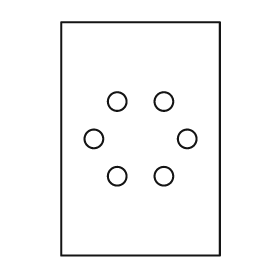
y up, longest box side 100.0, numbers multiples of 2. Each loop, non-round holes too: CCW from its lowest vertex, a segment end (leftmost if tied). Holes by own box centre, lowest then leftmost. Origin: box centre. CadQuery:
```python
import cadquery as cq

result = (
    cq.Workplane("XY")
    .moveTo(-34.0, -50.0)
    .lineTo(34.0, -50.0)
    .lineTo(34.0, 50.0)
    .lineTo(-34.0, 50.0)
    .close()
    .moveTo(-10.0, -16.0)
    .circle(4.0)
    .moveTo(10.0, -16.0)
    .circle(4.0)
    .moveTo(-20.0, 0.0)
    .circle(4.0)
    .moveTo(20.0, 0.0)
    .circle(4.0)
    .moveTo(-10.0, 16.0)
    .circle(4.0)
    .moveTo(10.0, 16.0)
    .circle(4.0)
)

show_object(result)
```